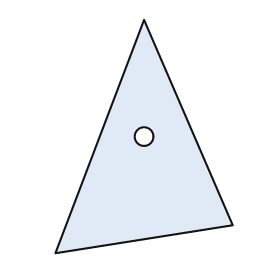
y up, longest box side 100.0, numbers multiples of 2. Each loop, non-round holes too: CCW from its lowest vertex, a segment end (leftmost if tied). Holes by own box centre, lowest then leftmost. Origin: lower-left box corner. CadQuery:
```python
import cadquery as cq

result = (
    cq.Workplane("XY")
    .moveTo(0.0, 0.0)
    .lineTo(76.0, 12.0)
    .lineTo(38.0, 100.0)
    .close()
    .moveTo(38.0, 50.0)
    .circle(4.0)
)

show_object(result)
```